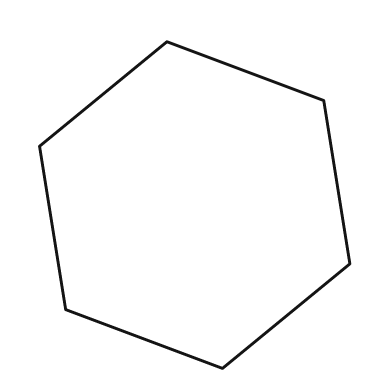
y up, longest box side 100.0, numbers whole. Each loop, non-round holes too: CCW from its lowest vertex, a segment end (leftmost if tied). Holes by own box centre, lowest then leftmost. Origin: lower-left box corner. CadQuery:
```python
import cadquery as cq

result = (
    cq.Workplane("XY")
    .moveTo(56.0, 0.0)
    .lineTo(95.0, 32.0)
    .lineTo(87.0, 82.0)
    .lineTo(39.0, 100.0)
    .lineTo(0.0, 68.0)
    .lineTo(8.0, 18.0)
    .close()
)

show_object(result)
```